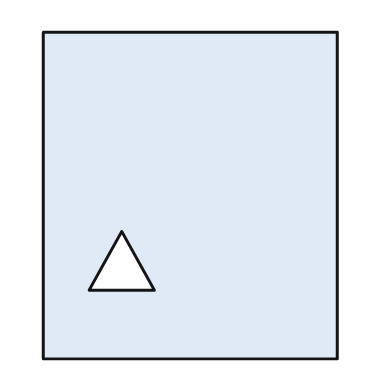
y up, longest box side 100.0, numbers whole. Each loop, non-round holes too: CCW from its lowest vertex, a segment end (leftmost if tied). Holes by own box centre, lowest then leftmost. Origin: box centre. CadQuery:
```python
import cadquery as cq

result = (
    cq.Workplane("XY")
    .moveTo(-45.0, -50.0)
    .lineTo(45.0, -50.0)
    .lineTo(45.0, 50.0)
    .lineTo(-45.0, 50.0)
    .close()
    .moveTo(-31.0, -29.0)
    .lineTo(-11.0, -29.0)
    .lineTo(-21.0, -11.0)
    .close()
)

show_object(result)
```